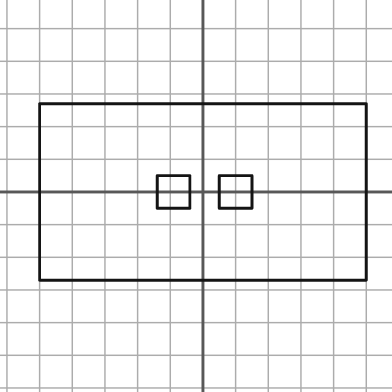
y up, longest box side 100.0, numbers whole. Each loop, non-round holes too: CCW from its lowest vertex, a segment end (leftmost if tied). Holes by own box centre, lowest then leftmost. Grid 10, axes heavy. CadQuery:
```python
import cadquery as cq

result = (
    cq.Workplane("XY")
    .moveTo(-50.0, -27.0)
    .lineTo(50.0, -27.0)
    .lineTo(50.0, 27.0)
    .lineTo(-50.0, 27.0)
    .close()
    .moveTo(-14.0, -5.0)
    .lineTo(-4.0, -5.0)
    .lineTo(-4.0, 5.0)
    .lineTo(-14.0, 5.0)
    .close()
    .moveTo(5.0, -5.0)
    .lineTo(15.0, -5.0)
    .lineTo(15.0, 5.0)
    .lineTo(5.0, 5.0)
    .close()
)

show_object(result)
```